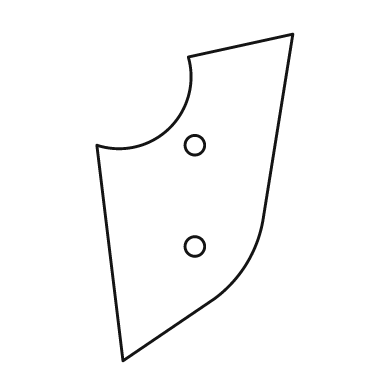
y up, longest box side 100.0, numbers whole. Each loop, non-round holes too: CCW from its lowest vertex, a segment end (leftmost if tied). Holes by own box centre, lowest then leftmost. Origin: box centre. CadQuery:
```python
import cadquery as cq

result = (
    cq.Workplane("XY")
    .moveTo(-22.0, -50.0)
    .lineTo(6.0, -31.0)
    .threePointArc((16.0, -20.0), (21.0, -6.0))
    .lineTo(30.0, 50.0)
    .lineTo(-2.0, 43.0)
    .threePointArc((-8.0, 21.0), (-30.0, 16.0))
    .close()
    .moveTo(0.0, -15.0)
    .circle(3.0)
    .moveTo(0.0, 16.0)
    .circle(3.0)
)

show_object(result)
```